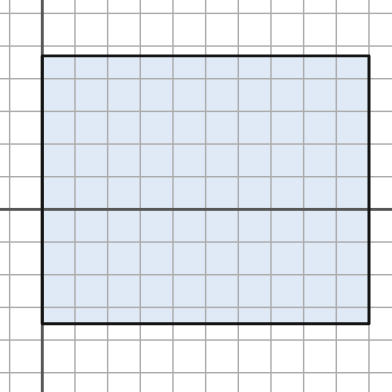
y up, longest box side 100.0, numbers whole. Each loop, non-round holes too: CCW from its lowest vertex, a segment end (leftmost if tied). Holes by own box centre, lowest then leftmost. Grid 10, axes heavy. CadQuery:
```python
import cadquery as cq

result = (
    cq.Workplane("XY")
    .moveTo(0.0, -35.0)
    .lineTo(100.0, -35.0)
    .lineTo(100.0, 47.0)
    .lineTo(0.0, 47.0)
    .close()
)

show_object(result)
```